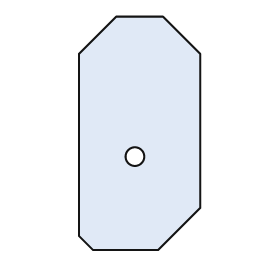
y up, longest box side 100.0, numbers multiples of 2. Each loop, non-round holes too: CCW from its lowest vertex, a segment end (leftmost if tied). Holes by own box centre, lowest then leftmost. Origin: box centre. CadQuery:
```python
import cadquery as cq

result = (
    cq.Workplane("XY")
    .moveTo(-20.0, -50.0)
    .lineTo(8.0, -50.0)
    .lineTo(26.0, -32.0)
    .lineTo(26.0, 34.0)
    .lineTo(10.0, 50.0)
    .lineTo(-10.0, 50.0)
    .lineTo(-26.0, 34.0)
    .lineTo(-26.0, -44.0)
    .close()
    .moveTo(-2.0, -10.0)
    .circle(4.0)
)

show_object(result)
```